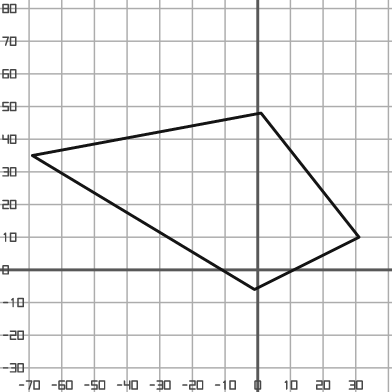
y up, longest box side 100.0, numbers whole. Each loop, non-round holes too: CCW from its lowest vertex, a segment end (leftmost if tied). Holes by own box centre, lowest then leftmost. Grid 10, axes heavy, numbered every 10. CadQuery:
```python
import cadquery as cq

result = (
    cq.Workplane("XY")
    .moveTo(-1.0, -6.0)
    .lineTo(31.0, 10.0)
    .lineTo(1.0, 48.0)
    .lineTo(-69.0, 35.0)
    .close()
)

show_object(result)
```